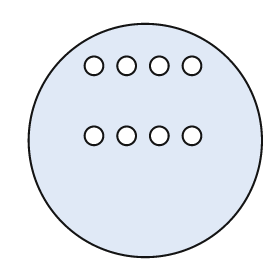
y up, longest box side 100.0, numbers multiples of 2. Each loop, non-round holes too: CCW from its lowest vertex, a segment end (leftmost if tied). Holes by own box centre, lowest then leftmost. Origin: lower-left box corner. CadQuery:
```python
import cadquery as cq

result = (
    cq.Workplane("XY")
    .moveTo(50.0, 50.0)
    .circle(50.0)
    .moveTo(28.0, 52.0)
    .circle(4.0)
    .moveTo(42.0, 52.0)
    .circle(4.0)
    .moveTo(56.0, 52.0)
    .circle(4.0)
    .moveTo(70.0, 52.0)
    .circle(4.0)
    .moveTo(28.0, 82.0)
    .circle(4.0)
    .moveTo(42.0, 82.0)
    .circle(4.0)
    .moveTo(56.0, 82.0)
    .circle(4.0)
    .moveTo(70.0, 82.0)
    .circle(4.0)
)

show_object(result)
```